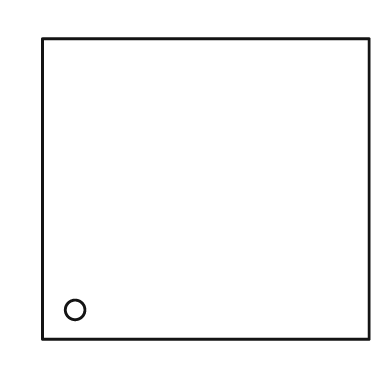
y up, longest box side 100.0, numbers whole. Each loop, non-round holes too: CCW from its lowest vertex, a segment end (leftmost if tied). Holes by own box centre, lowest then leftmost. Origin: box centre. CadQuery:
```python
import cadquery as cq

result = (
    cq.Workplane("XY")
    .moveTo(-50.0, -46.0)
    .lineTo(50.0, -46.0)
    .lineTo(50.0, 46.0)
    .lineTo(-50.0, 46.0)
    .close()
    .moveTo(-40.0, -37.0)
    .circle(3.0)
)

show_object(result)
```